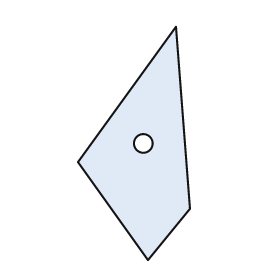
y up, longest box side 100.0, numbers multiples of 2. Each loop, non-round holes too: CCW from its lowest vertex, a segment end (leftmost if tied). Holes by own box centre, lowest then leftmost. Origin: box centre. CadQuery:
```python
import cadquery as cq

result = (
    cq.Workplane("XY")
    .moveTo(6.0, -50.0)
    .lineTo(24.0, -28.0)
    .lineTo(18.0, 50.0)
    .lineTo(-24.0, -8.0)
    .close()
    .moveTo(4.0, 0.0)
    .circle(4.0)
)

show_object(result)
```